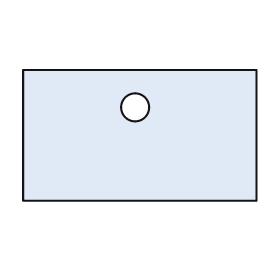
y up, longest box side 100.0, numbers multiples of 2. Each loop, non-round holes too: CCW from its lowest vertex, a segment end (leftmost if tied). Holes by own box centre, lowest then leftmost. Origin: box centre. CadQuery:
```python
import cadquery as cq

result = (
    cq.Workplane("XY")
    .moveTo(-50.0, -28.0)
    .lineTo(50.0, -28.0)
    .lineTo(50.0, 28.0)
    .lineTo(-50.0, 28.0)
    .close()
    .moveTo(-2.0, 12.0)
    .circle(6.0)
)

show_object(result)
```